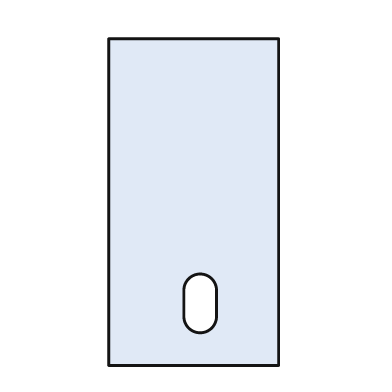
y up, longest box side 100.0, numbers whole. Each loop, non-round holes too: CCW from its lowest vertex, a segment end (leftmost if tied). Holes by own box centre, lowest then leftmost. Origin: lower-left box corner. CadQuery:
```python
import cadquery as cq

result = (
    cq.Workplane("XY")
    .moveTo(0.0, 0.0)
    .lineTo(52.0, 0.0)
    .lineTo(52.0, 100.0)
    .lineTo(0.0, 100.0)
    .close()
    .moveTo(23.0, 15.0)
    .threePointArc((28.0, 10.0), (33.0, 15.0))
    .lineTo(33.0, 23.0)
    .threePointArc((28.0, 28.0), (23.0, 23.0))
    .close()
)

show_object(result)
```